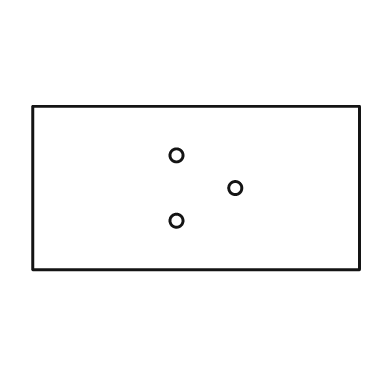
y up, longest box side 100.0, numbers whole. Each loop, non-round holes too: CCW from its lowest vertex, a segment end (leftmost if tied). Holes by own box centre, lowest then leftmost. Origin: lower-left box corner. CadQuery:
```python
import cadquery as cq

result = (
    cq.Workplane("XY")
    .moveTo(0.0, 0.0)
    .lineTo(100.0, 0.0)
    .lineTo(100.0, 50.0)
    .lineTo(0.0, 50.0)
    .close()
    .moveTo(44.0, 15.0)
    .circle(2.0)
    .moveTo(62.0, 25.0)
    .circle(2.0)
    .moveTo(44.0, 35.0)
    .circle(2.0)
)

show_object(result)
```